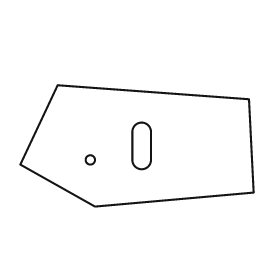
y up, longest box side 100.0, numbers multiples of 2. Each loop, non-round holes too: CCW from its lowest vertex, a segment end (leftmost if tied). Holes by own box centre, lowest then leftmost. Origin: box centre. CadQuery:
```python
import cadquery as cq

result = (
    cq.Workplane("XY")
    .moveTo(-18.0, -26.0)
    .lineTo(50.0, -20.0)
    .lineTo(48.0, 20.0)
    .lineTo(-34.0, 26.0)
    .lineTo(-50.0, -8.0)
    .close()
    .moveTo(-20.0, -6.0)
    .circle(2.0)
    .moveTo(-2.0, -6.0)
    .threePointArc((2.0, -10.0), (6.0, -6.0))
    .lineTo(6.0, 6.0)
    .threePointArc((2.0, 10.0), (-2.0, 6.0))
    .close()
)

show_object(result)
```